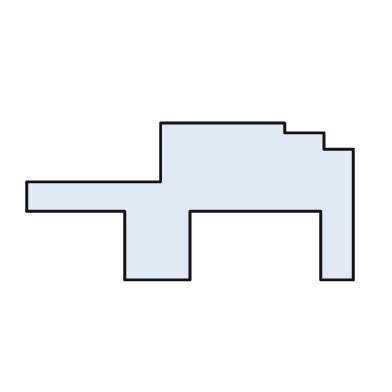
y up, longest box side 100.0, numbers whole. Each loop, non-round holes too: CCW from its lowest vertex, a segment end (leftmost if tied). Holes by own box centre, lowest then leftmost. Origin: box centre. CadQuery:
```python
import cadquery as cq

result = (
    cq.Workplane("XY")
    .moveTo(-20.0, -24.0)
    .lineTo(0.0, -24.0)
    .lineTo(0.0, -3.0)
    .lineTo(40.0, -3.0)
    .lineTo(40.0, -24.0)
    .lineTo(50.0, -24.0)
    .lineTo(50.0, 16.0)
    .lineTo(41.0, 16.0)
    .lineTo(41.0, 21.0)
    .lineTo(29.0, 21.0)
    .lineTo(29.0, 24.0)
    .lineTo(-9.0, 24.0)
    .lineTo(-9.0, 6.0)
    .lineTo(-50.0, 6.0)
    .lineTo(-50.0, -3.0)
    .lineTo(-20.0, -3.0)
    .close()
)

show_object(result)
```